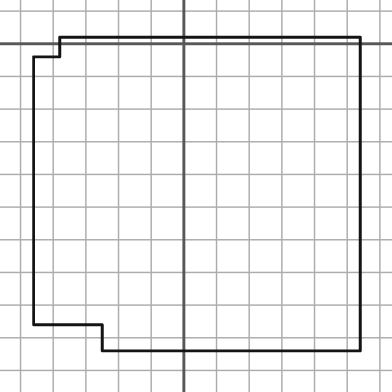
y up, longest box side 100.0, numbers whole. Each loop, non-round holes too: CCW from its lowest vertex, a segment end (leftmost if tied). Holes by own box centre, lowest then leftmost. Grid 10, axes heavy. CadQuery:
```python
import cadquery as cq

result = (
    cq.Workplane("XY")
    .moveTo(-25.0, -94.0)
    .lineTo(54.0, -94.0)
    .lineTo(54.0, 2.0)
    .lineTo(-38.0, 2.0)
    .lineTo(-38.0, -4.0)
    .lineTo(-46.0, -4.0)
    .lineTo(-46.0, -86.0)
    .lineTo(-25.0, -86.0)
    .close()
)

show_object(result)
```